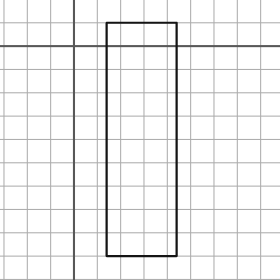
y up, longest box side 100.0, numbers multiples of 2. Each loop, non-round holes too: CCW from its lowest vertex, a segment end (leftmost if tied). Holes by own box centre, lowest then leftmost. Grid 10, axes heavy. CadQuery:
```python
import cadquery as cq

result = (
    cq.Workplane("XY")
    .moveTo(14.0, -90.0)
    .lineTo(44.0, -90.0)
    .lineTo(44.0, 10.0)
    .lineTo(14.0, 10.0)
    .close()
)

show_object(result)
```